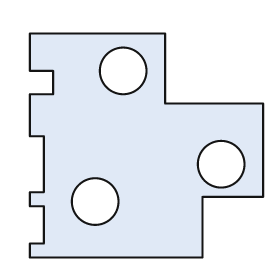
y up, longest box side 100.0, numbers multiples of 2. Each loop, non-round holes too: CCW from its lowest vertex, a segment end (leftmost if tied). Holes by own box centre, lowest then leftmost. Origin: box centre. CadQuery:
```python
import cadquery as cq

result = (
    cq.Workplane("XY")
    .moveTo(-50.0, -48.0)
    .lineTo(24.0, -48.0)
    .lineTo(24.0, -22.0)
    .lineTo(50.0, -22.0)
    .lineTo(50.0, 18.0)
    .lineTo(8.0, 18.0)
    .lineTo(8.0, 48.0)
    .lineTo(-50.0, 48.0)
    .lineTo(-50.0, 32.0)
    .lineTo(-40.0, 32.0)
    .lineTo(-40.0, 22.0)
    .lineTo(-50.0, 22.0)
    .lineTo(-50.0, 4.0)
    .lineTo(-44.0, 4.0)
    .lineTo(-44.0, -20.0)
    .lineTo(-50.0, -20.0)
    .lineTo(-50.0, -26.0)
    .lineTo(-44.0, -26.0)
    .lineTo(-44.0, -42.0)
    .lineTo(-50.0, -42.0)
    .close()
    .moveTo(-22.0, -24.0)
    .circle(10.0)
    .moveTo(32.0, -8.0)
    .circle(10.0)
    .moveTo(-10.0, 32.0)
    .circle(10.0)
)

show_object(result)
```